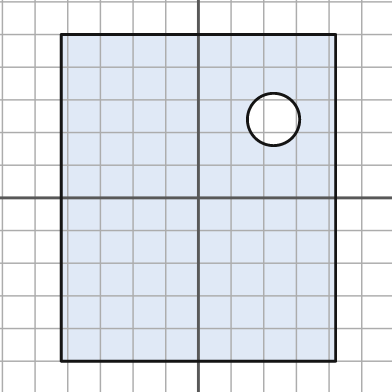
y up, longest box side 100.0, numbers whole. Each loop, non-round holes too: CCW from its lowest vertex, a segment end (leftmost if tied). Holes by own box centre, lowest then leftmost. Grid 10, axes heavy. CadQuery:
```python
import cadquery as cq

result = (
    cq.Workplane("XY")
    .moveTo(-42.0, -50.0)
    .lineTo(42.0, -50.0)
    .lineTo(42.0, 50.0)
    .lineTo(-42.0, 50.0)
    .close()
    .moveTo(23.0, 24.0)
    .circle(8.0)
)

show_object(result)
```